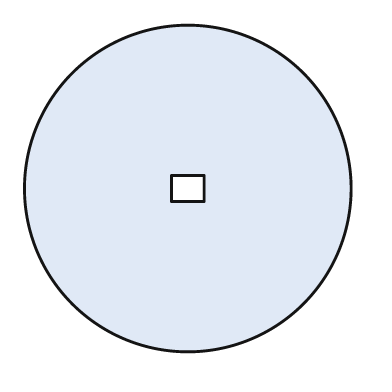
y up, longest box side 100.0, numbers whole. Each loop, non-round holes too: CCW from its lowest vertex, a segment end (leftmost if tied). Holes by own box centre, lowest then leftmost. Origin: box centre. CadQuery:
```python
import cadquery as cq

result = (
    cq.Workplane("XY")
    .moveTo(0.0, 0.0)
    .circle(50.0)
    .moveTo(-5.0, -4.0)
    .lineTo(5.0, -4.0)
    .lineTo(5.0, 4.0)
    .lineTo(-5.0, 4.0)
    .close()
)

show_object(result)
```